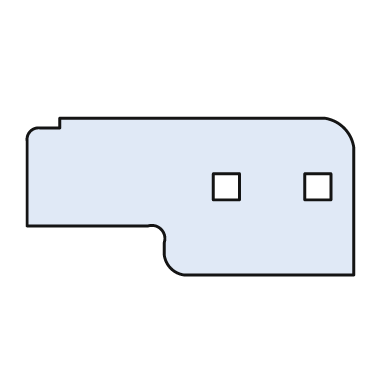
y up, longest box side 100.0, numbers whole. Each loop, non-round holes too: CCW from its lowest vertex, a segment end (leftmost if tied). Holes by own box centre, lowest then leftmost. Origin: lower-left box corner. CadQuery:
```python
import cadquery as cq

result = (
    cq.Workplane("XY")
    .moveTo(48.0, 0.0)
    .lineTo(100.0, 0.0)
    .lineTo(100.0, 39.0)
    .threePointArc((97.0, 45.0), (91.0, 48.0))
    .lineTo(10.0, 48.0)
    .lineTo(10.0, 45.0)
    .lineTo(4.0, 45.0)
    .threePointArc((1.0, 44.0), (0.0, 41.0))
    .lineTo(0.0, 15.0)
    .lineTo(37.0, 15.0)
    .threePointArc((41.0, 14.0), (42.0, 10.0))
    .lineTo(42.0, 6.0)
    .threePointArc((44.0, 2.0), (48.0, 0.0))
    .close()
    .moveTo(57.0, 23.0)
    .lineTo(65.0, 23.0)
    .lineTo(65.0, 31.0)
    .lineTo(57.0, 31.0)
    .close()
    .moveTo(85.0, 23.0)
    .lineTo(93.0, 23.0)
    .lineTo(93.0, 31.0)
    .lineTo(85.0, 31.0)
    .close()
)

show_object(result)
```